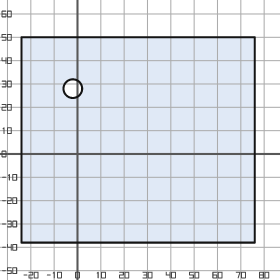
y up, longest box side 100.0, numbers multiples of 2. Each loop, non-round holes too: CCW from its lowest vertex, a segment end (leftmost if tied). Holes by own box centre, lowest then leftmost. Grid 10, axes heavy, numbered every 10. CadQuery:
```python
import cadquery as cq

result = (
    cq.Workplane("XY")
    .moveTo(-24.0, -38.0)
    .lineTo(76.0, -38.0)
    .lineTo(76.0, 50.0)
    .lineTo(-24.0, 50.0)
    .close()
    .moveTo(-2.0, 28.0)
    .circle(4.0)
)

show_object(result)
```